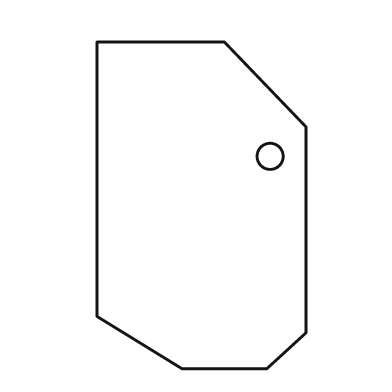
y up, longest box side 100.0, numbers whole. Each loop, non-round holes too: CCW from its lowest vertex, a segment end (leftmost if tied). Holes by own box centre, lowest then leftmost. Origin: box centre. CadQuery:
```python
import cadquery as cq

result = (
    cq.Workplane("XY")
    .moveTo(-6.0, -50.0)
    .lineTo(20.0, -50.0)
    .lineTo(32.0, -39.0)
    .lineTo(32.0, 24.0)
    .lineTo(7.0, 50.0)
    .lineTo(-32.0, 50.0)
    .lineTo(-32.0, -34.0)
    .close()
    .moveTo(21.0, 15.0)
    .circle(4.0)
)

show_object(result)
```